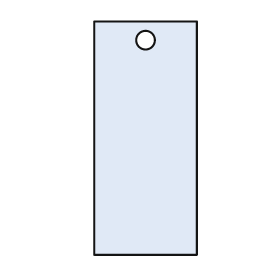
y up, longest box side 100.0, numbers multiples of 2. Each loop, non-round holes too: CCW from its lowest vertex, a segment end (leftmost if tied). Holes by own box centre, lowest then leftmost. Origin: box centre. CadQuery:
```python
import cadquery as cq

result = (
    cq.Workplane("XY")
    .moveTo(-22.0, -50.0)
    .lineTo(22.0, -50.0)
    .lineTo(22.0, 50.0)
    .lineTo(-22.0, 50.0)
    .close()
    .moveTo(0.0, 42.0)
    .circle(4.0)
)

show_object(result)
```